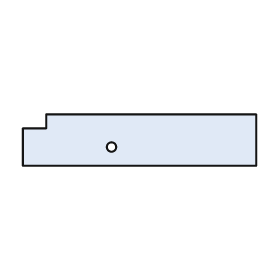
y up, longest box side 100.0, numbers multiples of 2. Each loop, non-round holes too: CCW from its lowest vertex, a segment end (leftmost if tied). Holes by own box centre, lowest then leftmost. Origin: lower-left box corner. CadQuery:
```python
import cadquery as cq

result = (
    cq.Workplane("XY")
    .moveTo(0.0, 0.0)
    .lineTo(100.0, 0.0)
    .lineTo(100.0, 22.0)
    .lineTo(10.0, 22.0)
    .lineTo(10.0, 16.0)
    .lineTo(0.0, 16.0)
    .close()
    .moveTo(38.0, 8.0)
    .circle(2.0)
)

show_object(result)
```